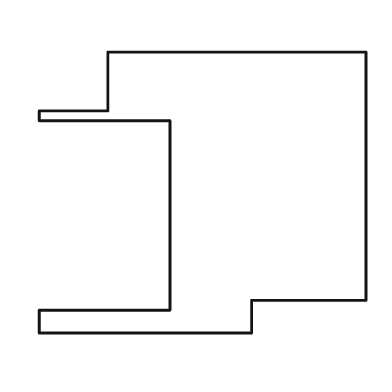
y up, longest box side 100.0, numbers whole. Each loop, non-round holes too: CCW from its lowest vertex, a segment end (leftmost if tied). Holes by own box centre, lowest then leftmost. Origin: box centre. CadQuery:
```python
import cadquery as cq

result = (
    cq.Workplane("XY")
    .moveTo(-50.0, -43.0)
    .lineTo(15.0, -43.0)
    .lineTo(15.0, -33.0)
    .lineTo(50.0, -33.0)
    .lineTo(50.0, 43.0)
    .lineTo(-29.0, 43.0)
    .lineTo(-29.0, 25.0)
    .lineTo(-50.0, 25.0)
    .lineTo(-50.0, 22.0)
    .lineTo(-10.0, 22.0)
    .lineTo(-10.0, -36.0)
    .lineTo(-50.0, -36.0)
    .close()
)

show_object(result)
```